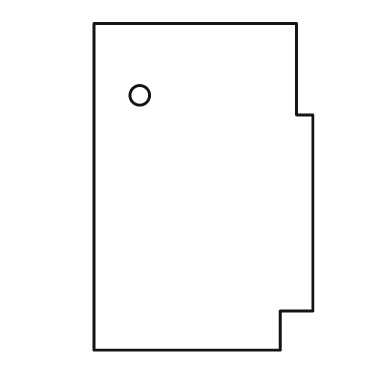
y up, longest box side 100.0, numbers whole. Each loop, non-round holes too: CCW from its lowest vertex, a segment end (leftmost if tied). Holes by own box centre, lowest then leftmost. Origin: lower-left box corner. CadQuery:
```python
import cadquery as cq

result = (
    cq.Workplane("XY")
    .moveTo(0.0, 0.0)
    .lineTo(57.0, 0.0)
    .lineTo(57.0, 12.0)
    .lineTo(67.0, 12.0)
    .lineTo(67.0, 72.0)
    .lineTo(62.0, 72.0)
    .lineTo(62.0, 100.0)
    .lineTo(0.0, 100.0)
    .close()
    .moveTo(14.0, 78.0)
    .circle(3.0)
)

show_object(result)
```